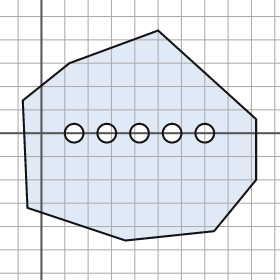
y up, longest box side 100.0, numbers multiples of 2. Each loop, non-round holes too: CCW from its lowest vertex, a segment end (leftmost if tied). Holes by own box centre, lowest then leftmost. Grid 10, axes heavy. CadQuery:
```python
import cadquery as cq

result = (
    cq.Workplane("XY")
    .moveTo(36.0, -46.0)
    .lineTo(74.0, -42.0)
    .lineTo(92.0, -20.0)
    .lineTo(92.0, 6.0)
    .lineTo(50.0, 44.0)
    .lineTo(12.0, 30.0)
    .lineTo(-8.0, 14.0)
    .lineTo(-6.0, -32.0)
    .close()
    .moveTo(14.0, 0.0)
    .circle(4.0)
    .moveTo(28.0, 0.0)
    .circle(4.0)
    .moveTo(42.0, 0.0)
    .circle(4.0)
    .moveTo(56.0, 0.0)
    .circle(4.0)
    .moveTo(70.0, 0.0)
    .circle(4.0)
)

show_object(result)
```